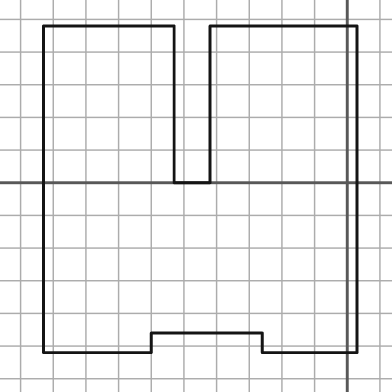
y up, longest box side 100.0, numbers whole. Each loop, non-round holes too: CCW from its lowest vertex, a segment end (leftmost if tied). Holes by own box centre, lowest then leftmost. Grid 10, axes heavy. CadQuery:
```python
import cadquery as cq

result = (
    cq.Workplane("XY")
    .moveTo(-93.0, -52.0)
    .lineTo(-60.0, -52.0)
    .lineTo(-60.0, -46.0)
    .lineTo(-26.0, -46.0)
    .lineTo(-26.0, -52.0)
    .lineTo(3.0, -52.0)
    .lineTo(3.0, 48.0)
    .lineTo(-42.0, 48.0)
    .lineTo(-42.0, 0.0)
    .lineTo(-53.0, 0.0)
    .lineTo(-53.0, 48.0)
    .lineTo(-93.0, 48.0)
    .close()
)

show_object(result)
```